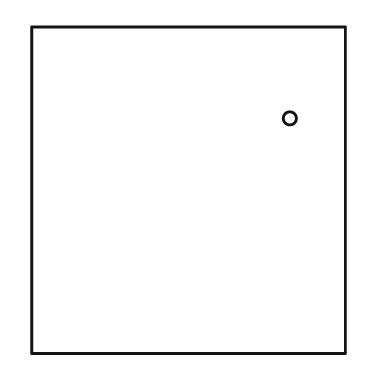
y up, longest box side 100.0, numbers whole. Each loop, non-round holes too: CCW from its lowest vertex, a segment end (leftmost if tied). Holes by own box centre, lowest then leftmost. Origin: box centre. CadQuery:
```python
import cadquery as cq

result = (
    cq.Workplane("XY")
    .moveTo(-48.0, -50.0)
    .lineTo(48.0, -50.0)
    .lineTo(48.0, 50.0)
    .lineTo(-48.0, 50.0)
    .close()
    .moveTo(31.0, 22.0)
    .circle(2.0)
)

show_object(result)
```